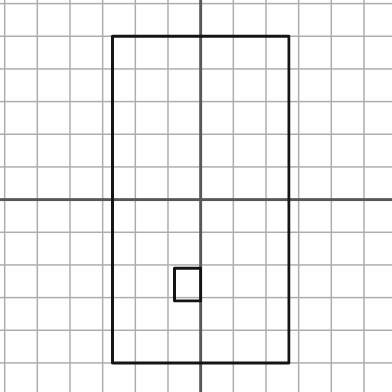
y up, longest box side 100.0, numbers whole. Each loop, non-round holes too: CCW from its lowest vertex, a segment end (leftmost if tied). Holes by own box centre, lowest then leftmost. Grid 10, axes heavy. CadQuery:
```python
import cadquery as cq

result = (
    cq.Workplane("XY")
    .moveTo(-27.0, -50.0)
    .lineTo(27.0, -50.0)
    .lineTo(27.0, 50.0)
    .lineTo(-27.0, 50.0)
    .close()
    .moveTo(-8.0, -31.0)
    .lineTo(0.0, -31.0)
    .lineTo(0.0, -21.0)
    .lineTo(-8.0, -21.0)
    .close()
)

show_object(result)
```